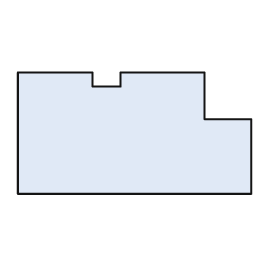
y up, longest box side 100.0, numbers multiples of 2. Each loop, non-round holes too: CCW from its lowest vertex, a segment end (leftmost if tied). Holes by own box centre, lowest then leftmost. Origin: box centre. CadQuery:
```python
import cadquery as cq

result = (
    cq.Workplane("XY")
    .moveTo(-50.0, -26.0)
    .lineTo(50.0, -26.0)
    .lineTo(50.0, 6.0)
    .lineTo(30.0, 6.0)
    .lineTo(30.0, 26.0)
    .lineTo(-6.0, 26.0)
    .lineTo(-6.0, 20.0)
    .lineTo(-18.0, 20.0)
    .lineTo(-18.0, 26.0)
    .lineTo(-50.0, 26.0)
    .close()
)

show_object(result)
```